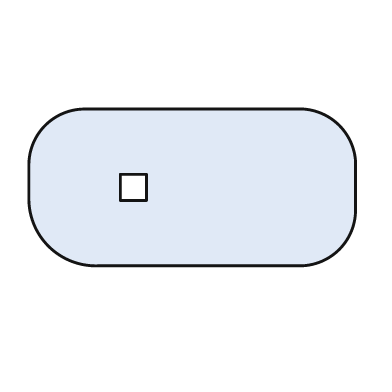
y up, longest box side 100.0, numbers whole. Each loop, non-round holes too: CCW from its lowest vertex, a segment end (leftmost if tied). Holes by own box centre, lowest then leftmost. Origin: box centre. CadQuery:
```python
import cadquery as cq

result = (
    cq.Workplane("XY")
    .moveTo(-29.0, -24.0)
    .lineTo(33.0, -24.0)
    .threePointArc((45.0, -19.0), (50.0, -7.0))
    .lineTo(50.0, 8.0)
    .threePointArc((45.0, 19.0), (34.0, 24.0))
    .lineTo(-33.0, 24.0)
    .threePointArc((-45.0, 19.0), (-50.0, 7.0))
    .lineTo(-50.0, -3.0)
    .threePointArc((-44.0, -18.0), (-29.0, -24.0))
    .close()
    .moveTo(-22.0, -4.0)
    .lineTo(-14.0, -4.0)
    .lineTo(-14.0, 4.0)
    .lineTo(-22.0, 4.0)
    .close()
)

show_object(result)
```